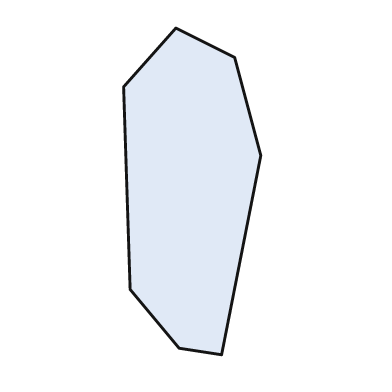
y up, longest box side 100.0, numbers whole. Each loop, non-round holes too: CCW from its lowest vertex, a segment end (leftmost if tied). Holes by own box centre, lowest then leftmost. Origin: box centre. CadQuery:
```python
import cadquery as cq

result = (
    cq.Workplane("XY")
    .moveTo(9.0, -50.0)
    .lineTo(21.0, 11.0)
    .lineTo(13.0, 41.0)
    .lineTo(-5.0, 50.0)
    .lineTo(-21.0, 32.0)
    .lineTo(-19.0, -30.0)
    .lineTo(-4.0, -48.0)
    .close()
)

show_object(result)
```